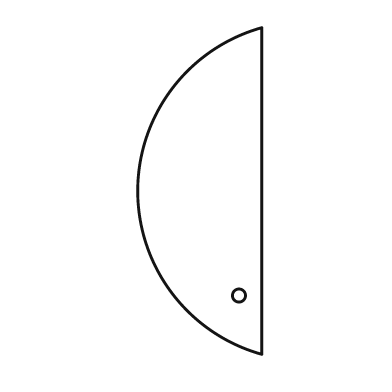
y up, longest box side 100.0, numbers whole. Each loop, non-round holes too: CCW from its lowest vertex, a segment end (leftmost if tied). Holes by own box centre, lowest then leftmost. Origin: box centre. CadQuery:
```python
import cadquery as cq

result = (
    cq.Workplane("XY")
    .moveTo(19.0, -50.0)
    .lineTo(19.0, 50.0)
    .threePointArc((-19.0, 0.0), (19.0, -50.0))
    .close()
    .moveTo(12.0, -32.0)
    .circle(2.0)
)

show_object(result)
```